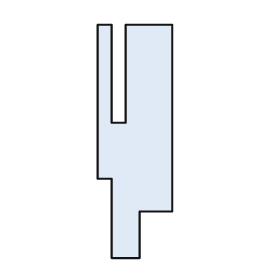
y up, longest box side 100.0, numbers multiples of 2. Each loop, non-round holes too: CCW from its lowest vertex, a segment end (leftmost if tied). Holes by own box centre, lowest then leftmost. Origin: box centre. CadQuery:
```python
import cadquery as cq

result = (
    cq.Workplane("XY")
    .moveTo(-10.0, -50.0)
    .lineTo(2.0, -50.0)
    .lineTo(2.0, -30.0)
    .lineTo(16.0, -30.0)
    .lineTo(16.0, 50.0)
    .lineTo(-4.0, 50.0)
    .lineTo(-4.0, 8.0)
    .lineTo(-10.0, 8.0)
    .lineTo(-10.0, 50.0)
    .lineTo(-16.0, 50.0)
    .lineTo(-16.0, -16.0)
    .lineTo(-10.0, -16.0)
    .close()
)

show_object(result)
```